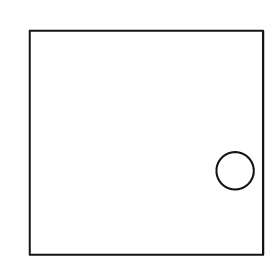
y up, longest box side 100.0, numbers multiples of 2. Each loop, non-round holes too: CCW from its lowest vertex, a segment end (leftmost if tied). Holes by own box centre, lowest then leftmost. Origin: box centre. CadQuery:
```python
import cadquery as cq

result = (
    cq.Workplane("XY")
    .moveTo(-50.0, -48.0)
    .lineTo(50.0, -48.0)
    .lineTo(50.0, 48.0)
    .lineTo(-50.0, 48.0)
    .close()
    .moveTo(38.0, -12.0)
    .circle(8.0)
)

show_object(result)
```